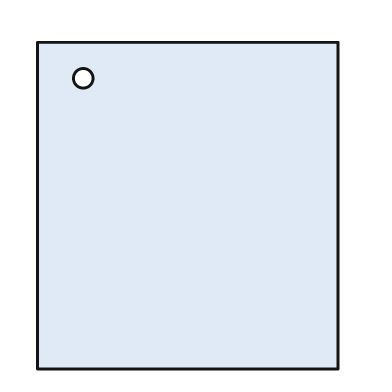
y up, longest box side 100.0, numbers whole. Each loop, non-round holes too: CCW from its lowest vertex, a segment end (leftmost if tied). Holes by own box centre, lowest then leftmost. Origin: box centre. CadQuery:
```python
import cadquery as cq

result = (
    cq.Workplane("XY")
    .moveTo(-46.0, -50.0)
    .lineTo(46.0, -50.0)
    .lineTo(46.0, 50.0)
    .lineTo(-46.0, 50.0)
    .close()
    .moveTo(-32.0, 39.0)
    .circle(3.0)
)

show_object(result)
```